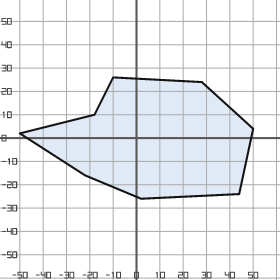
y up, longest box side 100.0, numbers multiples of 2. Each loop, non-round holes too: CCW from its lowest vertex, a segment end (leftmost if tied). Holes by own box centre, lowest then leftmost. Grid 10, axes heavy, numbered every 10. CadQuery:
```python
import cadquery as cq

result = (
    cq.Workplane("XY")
    .moveTo(2.0, -26.0)
    .lineTo(44.0, -24.0)
    .lineTo(50.0, 4.0)
    .lineTo(28.0, 24.0)
    .lineTo(-10.0, 26.0)
    .lineTo(-18.0, 10.0)
    .lineTo(-50.0, 2.0)
    .lineTo(-22.0, -16.0)
    .close()
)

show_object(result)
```